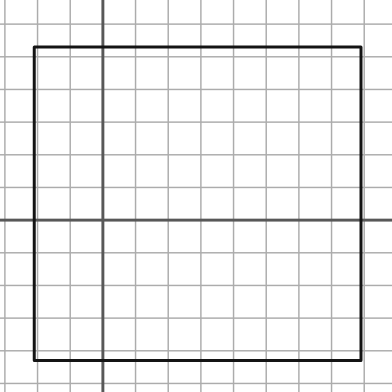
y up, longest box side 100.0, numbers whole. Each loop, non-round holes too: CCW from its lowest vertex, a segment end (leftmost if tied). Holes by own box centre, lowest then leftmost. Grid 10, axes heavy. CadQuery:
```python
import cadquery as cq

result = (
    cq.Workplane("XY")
    .moveTo(-21.0, -43.0)
    .lineTo(79.0, -43.0)
    .lineTo(79.0, 53.0)
    .lineTo(-21.0, 53.0)
    .close()
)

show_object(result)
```